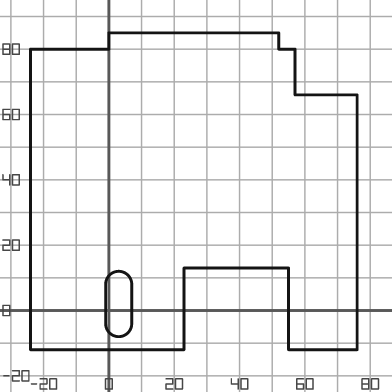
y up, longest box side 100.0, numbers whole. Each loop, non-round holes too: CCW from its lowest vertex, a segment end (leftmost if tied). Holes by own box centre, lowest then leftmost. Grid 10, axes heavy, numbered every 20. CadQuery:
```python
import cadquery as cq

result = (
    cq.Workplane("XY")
    .moveTo(-24.0, -12.0)
    .lineTo(23.0, -12.0)
    .lineTo(23.0, 13.0)
    .lineTo(55.0, 13.0)
    .lineTo(55.0, -12.0)
    .lineTo(76.0, -12.0)
    .lineTo(76.0, 66.0)
    .lineTo(57.0, 66.0)
    .lineTo(57.0, 80.0)
    .lineTo(52.0, 80.0)
    .lineTo(52.0, 85.0)
    .lineTo(0.0, 85.0)
    .lineTo(0.0, 80.0)
    .lineTo(-24.0, 80.0)
    .close()
    .moveTo(-1.0, -4.0)
    .threePointArc((3.0, -8.0), (7.0, -4.0))
    .lineTo(7.0, 8.0)
    .threePointArc((3.0, 12.0), (-1.0, 8.0))
    .close()
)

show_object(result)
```